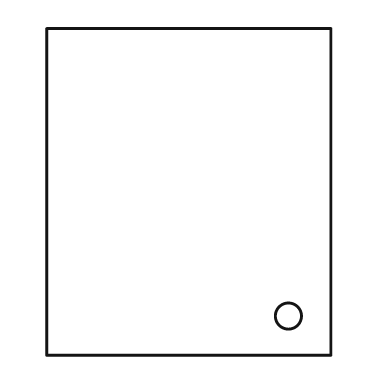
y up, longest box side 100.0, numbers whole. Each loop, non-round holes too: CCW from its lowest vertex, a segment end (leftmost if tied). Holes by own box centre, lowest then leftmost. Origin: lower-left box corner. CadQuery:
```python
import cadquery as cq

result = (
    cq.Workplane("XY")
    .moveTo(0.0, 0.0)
    .lineTo(87.0, 0.0)
    .lineTo(87.0, 100.0)
    .lineTo(0.0, 100.0)
    .close()
    .moveTo(74.0, 12.0)
    .circle(4.0)
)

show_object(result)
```